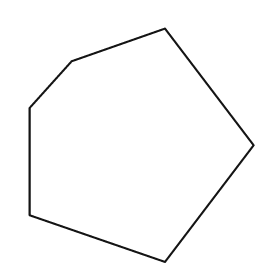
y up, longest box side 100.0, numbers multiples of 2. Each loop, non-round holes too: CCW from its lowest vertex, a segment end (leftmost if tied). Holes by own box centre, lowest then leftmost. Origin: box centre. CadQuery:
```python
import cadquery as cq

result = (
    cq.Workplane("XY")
    .moveTo(10.0, -50.0)
    .lineTo(48.0, 0.0)
    .lineTo(10.0, 50.0)
    .lineTo(-30.0, 36.0)
    .lineTo(-48.0, 16.0)
    .lineTo(-48.0, -30.0)
    .close()
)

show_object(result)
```